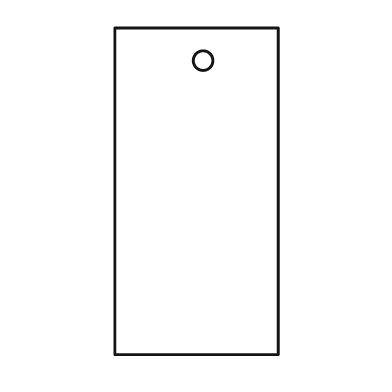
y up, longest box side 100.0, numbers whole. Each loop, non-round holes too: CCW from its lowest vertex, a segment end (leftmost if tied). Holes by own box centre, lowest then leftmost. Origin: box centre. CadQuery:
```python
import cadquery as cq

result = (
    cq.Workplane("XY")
    .moveTo(-25.0, -50.0)
    .lineTo(25.0, -50.0)
    .lineTo(25.0, 50.0)
    .lineTo(-25.0, 50.0)
    .close()
    .moveTo(2.0, 40.0)
    .circle(3.0)
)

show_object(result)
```